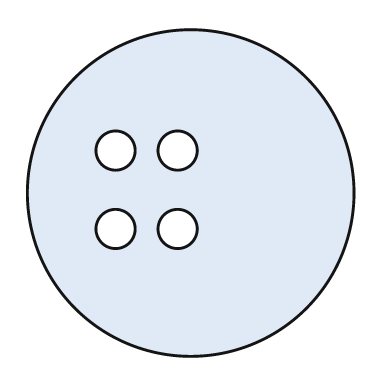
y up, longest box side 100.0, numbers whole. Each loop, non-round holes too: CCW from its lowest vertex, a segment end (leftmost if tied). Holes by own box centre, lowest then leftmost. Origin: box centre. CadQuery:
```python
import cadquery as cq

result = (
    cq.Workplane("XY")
    .moveTo(0.0, 0.0)
    .circle(50.0)
    .moveTo(-23.0, -11.0)
    .circle(6.0)
    .moveTo(-4.0, -11.0)
    .circle(6.0)
    .moveTo(-23.0, 13.0)
    .circle(6.0)
    .moveTo(-4.0, 13.0)
    .circle(6.0)
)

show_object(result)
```